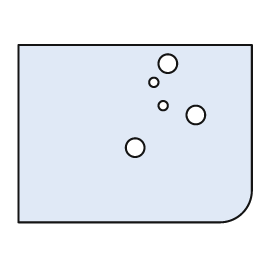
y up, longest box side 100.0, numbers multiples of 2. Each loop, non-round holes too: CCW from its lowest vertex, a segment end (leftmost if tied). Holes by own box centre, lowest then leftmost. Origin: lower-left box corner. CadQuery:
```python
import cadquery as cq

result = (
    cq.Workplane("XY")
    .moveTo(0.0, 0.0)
    .lineTo(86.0, 0.0)
    .threePointArc((96.0, 4.0), (100.0, 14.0))
    .lineTo(100.0, 76.0)
    .lineTo(0.0, 76.0)
    .close()
    .moveTo(50.0, 32.0)
    .circle(4.0)
    .moveTo(76.0, 46.0)
    .circle(4.0)
    .moveTo(62.0, 50.0)
    .circle(2.0)
    .moveTo(58.0, 60.0)
    .circle(2.0)
    .moveTo(64.0, 68.0)
    .circle(4.0)
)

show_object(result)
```